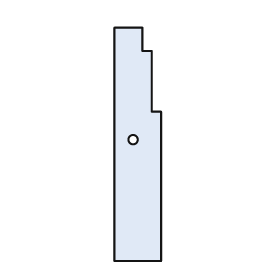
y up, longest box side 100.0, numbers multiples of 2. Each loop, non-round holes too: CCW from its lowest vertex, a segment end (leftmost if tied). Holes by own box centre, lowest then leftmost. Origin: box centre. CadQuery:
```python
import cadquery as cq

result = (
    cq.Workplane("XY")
    .moveTo(-10.0, -50.0)
    .lineTo(10.0, -50.0)
    .lineTo(10.0, 14.0)
    .lineTo(6.0, 14.0)
    .lineTo(6.0, 40.0)
    .lineTo(2.0, 40.0)
    .lineTo(2.0, 50.0)
    .lineTo(-10.0, 50.0)
    .close()
    .moveTo(-2.0, 2.0)
    .circle(2.0)
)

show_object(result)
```